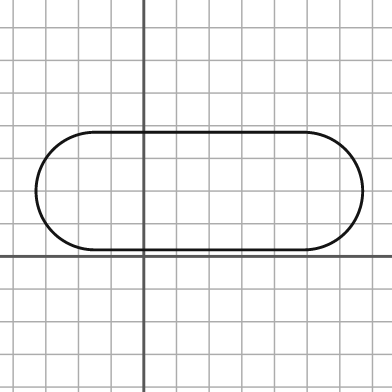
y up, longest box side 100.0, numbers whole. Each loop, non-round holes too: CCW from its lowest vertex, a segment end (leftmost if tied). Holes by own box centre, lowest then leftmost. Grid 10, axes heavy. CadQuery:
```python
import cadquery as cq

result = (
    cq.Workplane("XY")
    .moveTo(-15.0, 2.0)
    .lineTo(49.0, 2.0)
    .threePointArc((67.0, 20.0), (49.0, 38.0))
    .lineTo(-15.0, 38.0)
    .threePointArc((-33.0, 20.0), (-15.0, 2.0))
    .close()
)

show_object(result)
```